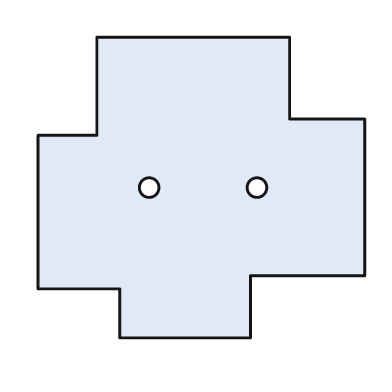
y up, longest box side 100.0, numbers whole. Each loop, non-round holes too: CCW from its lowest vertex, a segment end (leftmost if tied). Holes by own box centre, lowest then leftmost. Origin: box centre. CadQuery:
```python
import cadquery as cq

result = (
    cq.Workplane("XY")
    .moveTo(-25.0, -46.0)
    .lineTo(15.0, -46.0)
    .lineTo(15.0, -27.0)
    .lineTo(50.0, -27.0)
    .lineTo(50.0, 21.0)
    .lineTo(27.0, 21.0)
    .lineTo(27.0, 46.0)
    .lineTo(-32.0, 46.0)
    .lineTo(-32.0, 16.0)
    .lineTo(-50.0, 16.0)
    .lineTo(-50.0, -31.0)
    .lineTo(-25.0, -31.0)
    .close()
    .moveTo(-16.0, 0.0)
    .circle(3.0)
    .moveTo(17.0, 0.0)
    .circle(3.0)
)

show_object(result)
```